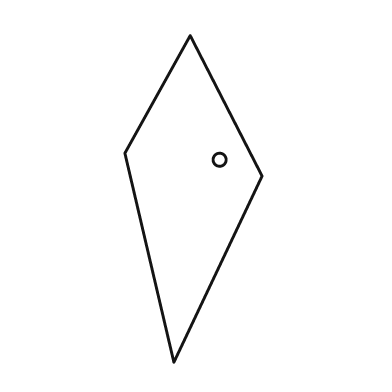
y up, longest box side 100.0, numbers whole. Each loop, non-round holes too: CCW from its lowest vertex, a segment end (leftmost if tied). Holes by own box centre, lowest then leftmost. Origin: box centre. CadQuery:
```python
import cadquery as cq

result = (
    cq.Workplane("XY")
    .moveTo(-6.0, -50.0)
    .lineTo(21.0, 7.0)
    .lineTo(-1.0, 50.0)
    .lineTo(-21.0, 14.0)
    .close()
    .moveTo(8.0, 12.0)
    .circle(2.0)
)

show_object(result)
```